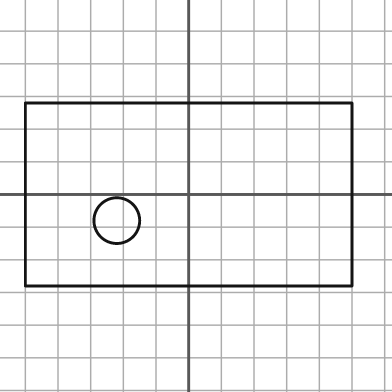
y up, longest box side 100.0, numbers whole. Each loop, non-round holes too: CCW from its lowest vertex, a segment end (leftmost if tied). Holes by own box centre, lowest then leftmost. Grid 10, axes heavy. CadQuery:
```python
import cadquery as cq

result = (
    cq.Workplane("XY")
    .moveTo(-50.0, -28.0)
    .lineTo(50.0, -28.0)
    .lineTo(50.0, 28.0)
    .lineTo(-50.0, 28.0)
    .close()
    .moveTo(-22.0, -8.0)
    .circle(7.0)
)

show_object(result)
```